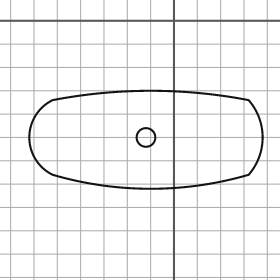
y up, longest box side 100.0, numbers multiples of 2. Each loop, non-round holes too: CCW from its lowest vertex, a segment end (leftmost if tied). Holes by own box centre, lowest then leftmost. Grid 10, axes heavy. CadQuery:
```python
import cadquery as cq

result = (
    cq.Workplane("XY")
    .moveTo(-52.0, -66.0)
    .threePointArc((-10.0, -72.0), (32.0, -66.0))
    .threePointArc((38.0, -50.0), (32.0, -34.0))
    .threePointArc((-10.0, -30.0), (-52.0, -34.0))
    .threePointArc((-62.0, -50.0), (-52.0, -66.0))
    .close()
    .moveTo(-12.0, -50.0)
    .circle(4.0)
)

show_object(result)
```